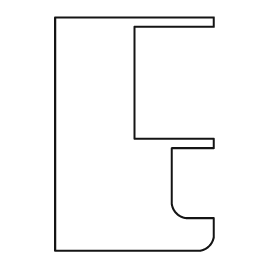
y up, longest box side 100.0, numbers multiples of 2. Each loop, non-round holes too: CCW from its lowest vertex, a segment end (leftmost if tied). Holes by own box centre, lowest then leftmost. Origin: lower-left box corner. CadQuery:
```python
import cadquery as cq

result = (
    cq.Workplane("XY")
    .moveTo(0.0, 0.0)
    .lineTo(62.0, 0.0)
    .threePointArc((66.0, 2.0), (68.0, 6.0))
    .lineTo(68.0, 14.0)
    .lineTo(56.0, 14.0)
    .threePointArc((52.0, 16.0), (50.0, 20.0))
    .lineTo(50.0, 44.0)
    .lineTo(68.0, 44.0)
    .lineTo(68.0, 48.0)
    .lineTo(34.0, 48.0)
    .lineTo(34.0, 96.0)
    .lineTo(68.0, 96.0)
    .lineTo(68.0, 100.0)
    .lineTo(0.0, 100.0)
    .close()
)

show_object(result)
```